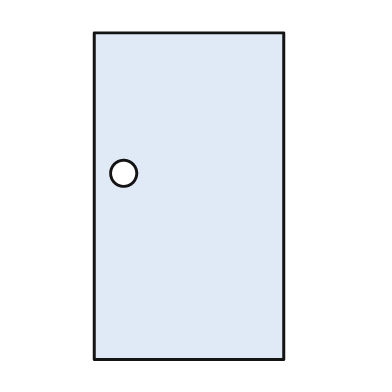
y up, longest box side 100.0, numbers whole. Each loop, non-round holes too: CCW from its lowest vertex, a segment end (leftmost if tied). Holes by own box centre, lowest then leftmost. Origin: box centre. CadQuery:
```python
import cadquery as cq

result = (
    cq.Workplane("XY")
    .moveTo(-29.0, -50.0)
    .lineTo(29.0, -50.0)
    .lineTo(29.0, 50.0)
    .lineTo(-29.0, 50.0)
    .close()
    .moveTo(-20.0, 7.0)
    .circle(4.0)
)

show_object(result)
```